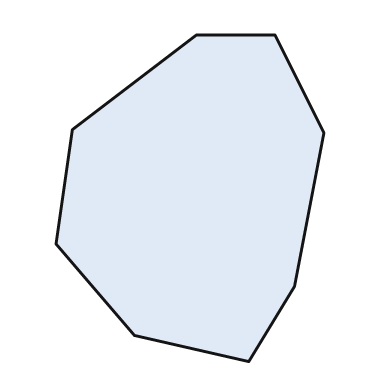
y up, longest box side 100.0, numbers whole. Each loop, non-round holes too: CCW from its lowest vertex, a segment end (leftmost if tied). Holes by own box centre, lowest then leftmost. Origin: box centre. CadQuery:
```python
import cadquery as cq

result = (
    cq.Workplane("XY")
    .moveTo(18.0, -50.0)
    .lineTo(32.0, -27.0)
    .lineTo(41.0, 20.0)
    .lineTo(26.0, 50.0)
    .lineTo(2.0, 50.0)
    .lineTo(-36.0, 21.0)
    .lineTo(-41.0, -14.0)
    .lineTo(-17.0, -42.0)
    .close()
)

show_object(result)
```